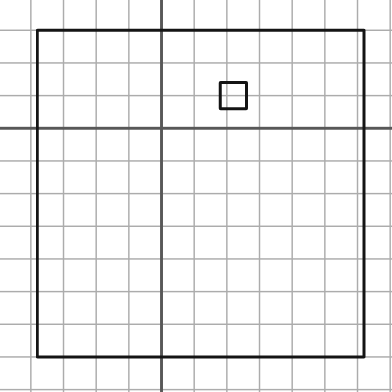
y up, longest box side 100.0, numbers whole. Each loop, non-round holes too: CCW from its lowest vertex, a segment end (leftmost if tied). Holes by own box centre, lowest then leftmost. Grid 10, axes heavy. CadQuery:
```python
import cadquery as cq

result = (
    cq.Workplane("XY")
    .moveTo(-38.0, -70.0)
    .lineTo(62.0, -70.0)
    .lineTo(62.0, 30.0)
    .lineTo(-38.0, 30.0)
    .close()
    .moveTo(18.0, 6.0)
    .lineTo(26.0, 6.0)
    .lineTo(26.0, 14.0)
    .lineTo(18.0, 14.0)
    .close()
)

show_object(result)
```